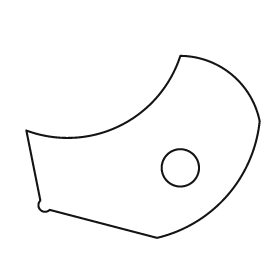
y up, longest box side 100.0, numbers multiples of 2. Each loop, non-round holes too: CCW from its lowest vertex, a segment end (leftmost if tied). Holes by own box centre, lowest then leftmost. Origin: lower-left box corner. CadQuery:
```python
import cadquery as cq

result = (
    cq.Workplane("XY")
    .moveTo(56.0, 0.0)
    .threePointArc((86.0, 18.0), (100.0, 50.0))
    .threePointArc((88.0, 70.0), (66.0, 78.0))
    .threePointArc((40.0, 48.0), (0.0, 46.0))
    .lineTo(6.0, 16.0)
    .threePointArc((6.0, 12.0), (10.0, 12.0))
    .close()
    .moveTo(66.0, 30.0)
    .circle(8.0)
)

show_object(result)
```